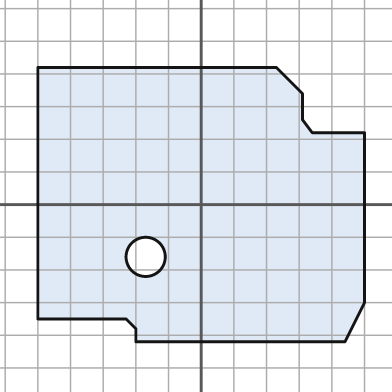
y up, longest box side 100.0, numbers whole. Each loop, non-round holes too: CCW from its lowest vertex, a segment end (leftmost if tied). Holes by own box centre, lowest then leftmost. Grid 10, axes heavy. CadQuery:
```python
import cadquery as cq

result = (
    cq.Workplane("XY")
    .moveTo(-20.0, -42.0)
    .lineTo(44.0, -42.0)
    .lineTo(50.0, -30.0)
    .lineTo(50.0, 22.0)
    .lineTo(34.0, 22.0)
    .lineTo(31.0, 26.0)
    .lineTo(31.0, 34.0)
    .lineTo(23.0, 42.0)
    .lineTo(-50.0, 42.0)
    .lineTo(-50.0, -35.0)
    .lineTo(-23.0, -35.0)
    .lineTo(-20.0, -38.0)
    .close()
    .moveTo(-17.0, -16.0)
    .circle(6.0)
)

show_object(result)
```